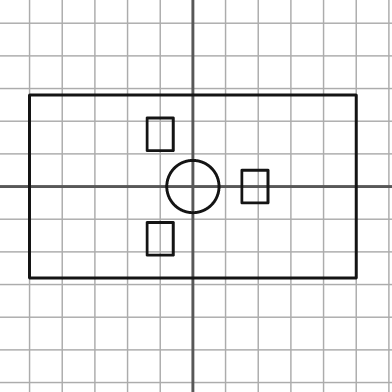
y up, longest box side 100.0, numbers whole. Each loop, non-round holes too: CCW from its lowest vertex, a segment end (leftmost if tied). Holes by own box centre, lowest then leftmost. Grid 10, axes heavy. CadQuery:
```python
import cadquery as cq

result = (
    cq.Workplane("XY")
    .moveTo(-50.0, -28.0)
    .lineTo(50.0, -28.0)
    .lineTo(50.0, 28.0)
    .lineTo(-50.0, 28.0)
    .close()
    .moveTo(-14.0, -21.0)
    .lineTo(-6.0, -21.0)
    .lineTo(-6.0, -11.0)
    .lineTo(-14.0, -11.0)
    .close()
    .moveTo(0.0, 0.0)
    .circle(8.0)
    .moveTo(15.0, -5.0)
    .lineTo(23.0, -5.0)
    .lineTo(23.0, 5.0)
    .lineTo(15.0, 5.0)
    .close()
    .moveTo(-14.0, 11.0)
    .lineTo(-6.0, 11.0)
    .lineTo(-6.0, 21.0)
    .lineTo(-14.0, 21.0)
    .close()
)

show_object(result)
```